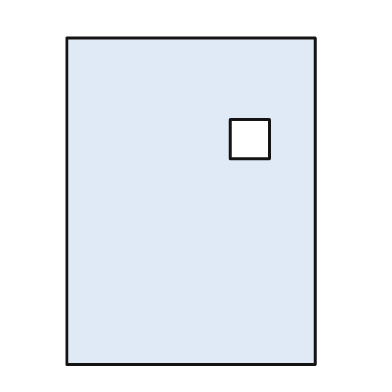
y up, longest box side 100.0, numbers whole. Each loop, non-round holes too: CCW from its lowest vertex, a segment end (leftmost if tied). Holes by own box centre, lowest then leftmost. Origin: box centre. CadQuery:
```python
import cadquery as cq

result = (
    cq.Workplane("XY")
    .moveTo(-38.0, -50.0)
    .lineTo(38.0, -50.0)
    .lineTo(38.0, 50.0)
    .lineTo(-38.0, 50.0)
    .close()
    .moveTo(12.0, 13.0)
    .lineTo(24.0, 13.0)
    .lineTo(24.0, 25.0)
    .lineTo(12.0, 25.0)
    .close()
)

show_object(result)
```